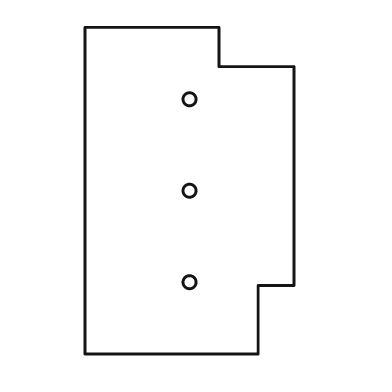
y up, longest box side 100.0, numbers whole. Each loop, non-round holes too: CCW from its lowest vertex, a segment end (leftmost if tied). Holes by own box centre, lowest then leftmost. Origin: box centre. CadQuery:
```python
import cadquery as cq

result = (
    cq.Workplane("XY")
    .moveTo(-32.0, -50.0)
    .lineTo(21.0, -50.0)
    .lineTo(21.0, -29.0)
    .lineTo(32.0, -29.0)
    .lineTo(32.0, 38.0)
    .lineTo(9.0, 38.0)
    .lineTo(9.0, 50.0)
    .lineTo(-32.0, 50.0)
    .close()
    .moveTo(0.0, -28.0)
    .circle(2.0)
    .moveTo(0.0, 0.0)
    .circle(2.0)
    .moveTo(0.0, 28.0)
    .circle(2.0)
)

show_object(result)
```